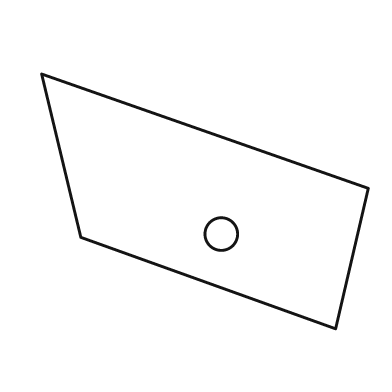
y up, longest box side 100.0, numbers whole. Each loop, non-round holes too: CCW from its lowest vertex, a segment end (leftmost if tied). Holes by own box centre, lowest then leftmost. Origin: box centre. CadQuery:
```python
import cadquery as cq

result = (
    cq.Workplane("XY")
    .moveTo(40.0, -39.0)
    .lineTo(50.0, 4.0)
    .lineTo(-50.0, 39.0)
    .lineTo(-38.0, -11.0)
    .close()
    .moveTo(5.0, -10.0)
    .circle(5.0)
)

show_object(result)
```